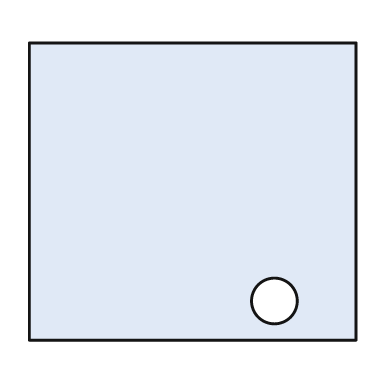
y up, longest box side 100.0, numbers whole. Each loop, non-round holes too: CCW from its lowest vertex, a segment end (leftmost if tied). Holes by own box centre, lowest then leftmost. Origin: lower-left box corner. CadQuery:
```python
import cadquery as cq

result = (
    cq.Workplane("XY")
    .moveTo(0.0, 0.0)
    .lineTo(100.0, 0.0)
    .lineTo(100.0, 91.0)
    .lineTo(0.0, 91.0)
    .close()
    .moveTo(75.0, 12.0)
    .circle(7.0)
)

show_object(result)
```